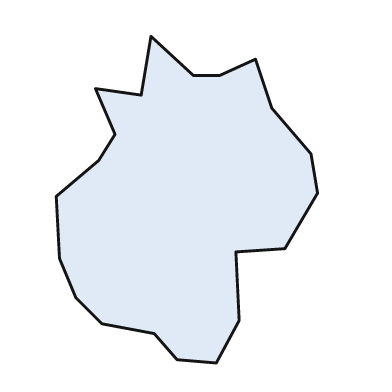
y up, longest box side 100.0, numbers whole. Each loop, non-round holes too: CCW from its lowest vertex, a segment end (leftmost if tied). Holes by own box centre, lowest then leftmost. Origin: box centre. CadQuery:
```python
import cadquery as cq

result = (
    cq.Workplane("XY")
    .moveTo(9.0, -50.0)
    .lineTo(16.0, -37.0)
    .lineTo(15.0, -16.0)
    .lineTo(30.0, -15.0)
    .lineTo(40.0, 2.0)
    .lineTo(38.0, 14.0)
    .lineTo(26.0, 28.0)
    .lineTo(21.0, 43.0)
    .lineTo(10.0, 38.0)
    .lineTo(2.0, 38.0)
    .lineTo(-11.0, 50.0)
    .lineTo(-14.0, 32.0)
    .lineTo(-28.0, 34.0)
    .lineTo(-22.0, 20.0)
    .lineTo(-27.0, 12.0)
    .lineTo(-40.0, 1.0)
    .lineTo(-39.0, -18.0)
    .lineTo(-34.0, -30.0)
    .lineTo(-26.0, -38.0)
    .lineTo(-10.0, -41.0)
    .lineTo(-3.0, -49.0)
    .close()
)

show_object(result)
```